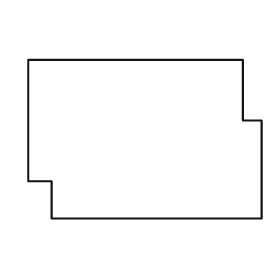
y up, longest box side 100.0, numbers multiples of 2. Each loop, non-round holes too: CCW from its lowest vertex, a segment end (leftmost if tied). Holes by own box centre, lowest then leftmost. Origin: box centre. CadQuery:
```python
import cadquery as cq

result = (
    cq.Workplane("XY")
    .moveTo(-40.0, -34.0)
    .lineTo(50.0, -34.0)
    .lineTo(50.0, 8.0)
    .lineTo(42.0, 8.0)
    .lineTo(42.0, 34.0)
    .lineTo(-50.0, 34.0)
    .lineTo(-50.0, -18.0)
    .lineTo(-40.0, -18.0)
    .close()
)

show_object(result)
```